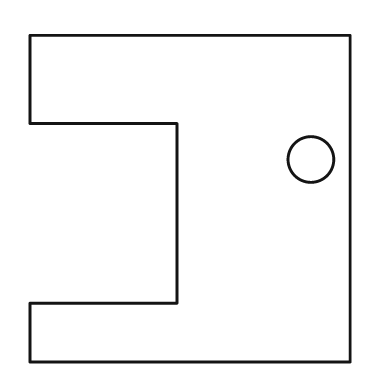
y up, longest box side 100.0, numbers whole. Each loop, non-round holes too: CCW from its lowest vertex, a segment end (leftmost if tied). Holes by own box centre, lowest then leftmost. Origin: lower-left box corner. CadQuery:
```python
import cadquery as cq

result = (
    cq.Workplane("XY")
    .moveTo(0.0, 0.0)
    .lineTo(98.0, 0.0)
    .lineTo(98.0, 100.0)
    .lineTo(0.0, 100.0)
    .lineTo(0.0, 73.0)
    .lineTo(45.0, 73.0)
    .lineTo(45.0, 18.0)
    .lineTo(0.0, 18.0)
    .close()
    .moveTo(86.0, 62.0)
    .circle(7.0)
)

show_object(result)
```